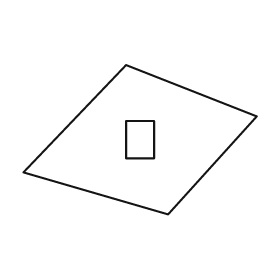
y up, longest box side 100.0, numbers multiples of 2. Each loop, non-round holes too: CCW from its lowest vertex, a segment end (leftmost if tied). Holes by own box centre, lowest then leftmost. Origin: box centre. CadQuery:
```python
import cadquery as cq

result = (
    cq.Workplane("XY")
    .moveTo(12.0, -32.0)
    .lineTo(50.0, 10.0)
    .lineTo(-6.0, 32.0)
    .lineTo(-50.0, -14.0)
    .close()
    .moveTo(-6.0, -8.0)
    .lineTo(6.0, -8.0)
    .lineTo(6.0, 8.0)
    .lineTo(-6.0, 8.0)
    .close()
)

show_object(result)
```